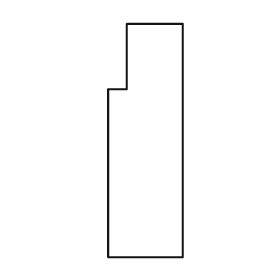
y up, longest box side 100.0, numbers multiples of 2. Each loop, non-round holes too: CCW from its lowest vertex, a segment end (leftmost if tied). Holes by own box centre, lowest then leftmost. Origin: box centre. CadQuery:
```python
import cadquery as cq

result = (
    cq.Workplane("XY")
    .moveTo(-16.0, -50.0)
    .lineTo(16.0, -50.0)
    .lineTo(16.0, 50.0)
    .lineTo(-8.0, 50.0)
    .lineTo(-8.0, 22.0)
    .lineTo(-16.0, 22.0)
    .close()
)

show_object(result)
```